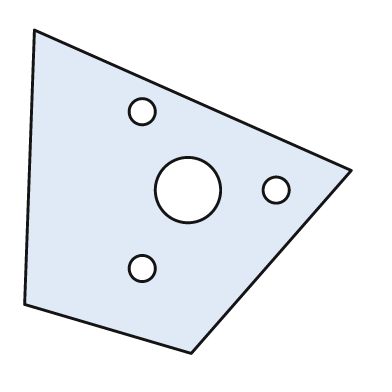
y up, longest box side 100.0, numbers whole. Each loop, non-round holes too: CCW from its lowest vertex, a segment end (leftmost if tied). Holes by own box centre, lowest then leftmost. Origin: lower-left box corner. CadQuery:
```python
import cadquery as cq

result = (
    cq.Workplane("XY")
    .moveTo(51.0, 0.0)
    .lineTo(100.0, 56.0)
    .lineTo(3.0, 99.0)
    .lineTo(0.0, 15.0)
    .close()
    .moveTo(36.0, 26.0)
    .circle(4.0)
    .moveTo(50.0, 50.0)
    .circle(10.0)
    .moveTo(77.0, 50.0)
    .circle(4.0)
    .moveTo(36.0, 74.0)
    .circle(4.0)
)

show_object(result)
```